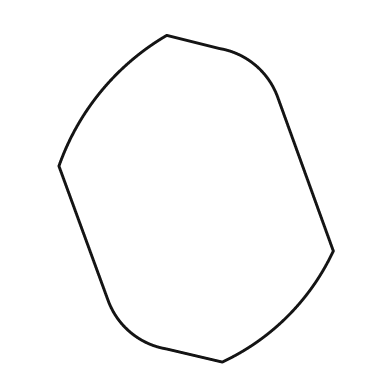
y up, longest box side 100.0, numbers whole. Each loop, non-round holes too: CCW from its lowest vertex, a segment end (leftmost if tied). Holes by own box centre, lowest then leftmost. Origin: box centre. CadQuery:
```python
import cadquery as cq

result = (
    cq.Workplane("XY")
    .moveTo(8.0, -50.0)
    .threePointArc((28.0, -36.0), (42.0, -16.0))
    .lineTo(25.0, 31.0)
    .threePointArc((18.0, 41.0), (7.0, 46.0))
    .lineTo(-9.0, 50.0)
    .threePointArc((-29.0, 33.0), (-42.0, 10.0))
    .lineTo(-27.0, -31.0)
    .threePointArc((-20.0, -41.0), (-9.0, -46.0))
    .close()
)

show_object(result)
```